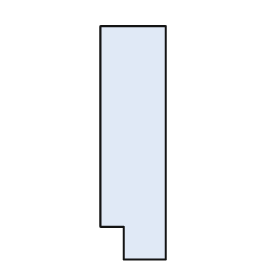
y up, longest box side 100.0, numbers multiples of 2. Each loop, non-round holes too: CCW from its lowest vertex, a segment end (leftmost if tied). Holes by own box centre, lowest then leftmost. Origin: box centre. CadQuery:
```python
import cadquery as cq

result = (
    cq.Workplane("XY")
    .moveTo(-4.0, -50.0)
    .lineTo(14.0, -50.0)
    .lineTo(14.0, 50.0)
    .lineTo(-14.0, 50.0)
    .lineTo(-14.0, -36.0)
    .lineTo(-4.0, -36.0)
    .close()
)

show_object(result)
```